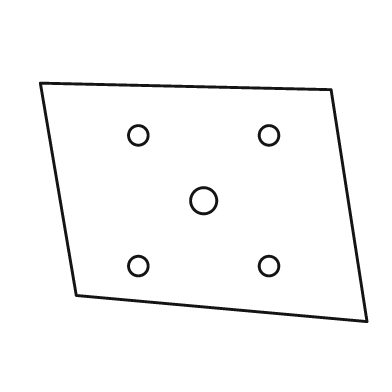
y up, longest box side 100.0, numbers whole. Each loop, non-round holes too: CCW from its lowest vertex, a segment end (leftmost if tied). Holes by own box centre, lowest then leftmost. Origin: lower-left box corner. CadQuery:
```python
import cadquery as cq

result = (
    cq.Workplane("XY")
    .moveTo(100.0, 0.0)
    .lineTo(89.0, 71.0)
    .lineTo(0.0, 73.0)
    .lineTo(11.0, 8.0)
    .close()
    .moveTo(30.0, 17.0)
    .circle(3.0)
    .moveTo(70.0, 17.0)
    .circle(3.0)
    .moveTo(50.0, 37.0)
    .circle(4.0)
    .moveTo(30.0, 57.0)
    .circle(3.0)
    .moveTo(70.0, 57.0)
    .circle(3.0)
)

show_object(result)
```